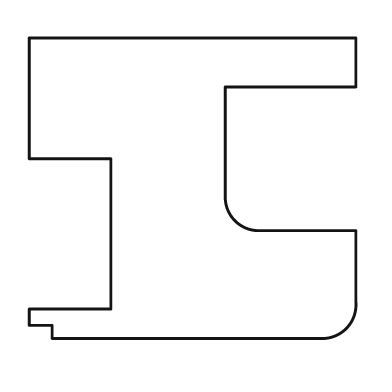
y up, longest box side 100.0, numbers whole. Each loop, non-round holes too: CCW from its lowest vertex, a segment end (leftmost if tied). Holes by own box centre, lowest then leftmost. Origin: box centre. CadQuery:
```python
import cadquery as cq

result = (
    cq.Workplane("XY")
    .moveTo(-43.0, -46.0)
    .lineTo(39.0, -46.0)
    .threePointArc((47.0, -43.0), (50.0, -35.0))
    .lineTo(50.0, -13.0)
    .lineTo(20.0, -13.0)
    .threePointArc((13.0, -10.0), (10.0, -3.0))
    .lineTo(10.0, 31.0)
    .lineTo(50.0, 31.0)
    .lineTo(50.0, 46.0)
    .lineTo(-50.0, 46.0)
    .lineTo(-50.0, 9.0)
    .lineTo(-25.0, 9.0)
    .lineTo(-25.0, -37.0)
    .lineTo(-50.0, -37.0)
    .lineTo(-50.0, -42.0)
    .lineTo(-43.0, -42.0)
    .close()
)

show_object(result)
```